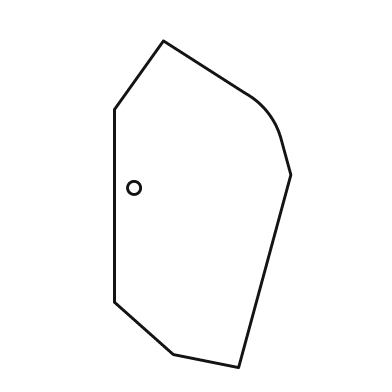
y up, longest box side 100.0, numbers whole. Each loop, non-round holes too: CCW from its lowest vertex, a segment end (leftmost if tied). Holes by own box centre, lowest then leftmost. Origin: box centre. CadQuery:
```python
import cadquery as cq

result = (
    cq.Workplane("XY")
    .moveTo(11.0, -50.0)
    .lineTo(27.0, 9.0)
    .lineTo(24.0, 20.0)
    .threePointArc((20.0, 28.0), (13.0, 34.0))
    .lineTo(-12.0, 50.0)
    .lineTo(-27.0, 29.0)
    .lineTo(-27.0, -30.0)
    .lineTo(-9.0, -46.0)
    .close()
    .moveTo(-21.0, 5.0)
    .circle(2.0)
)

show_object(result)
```